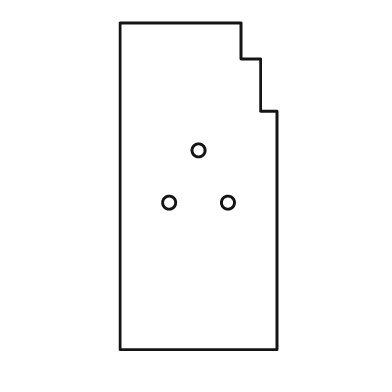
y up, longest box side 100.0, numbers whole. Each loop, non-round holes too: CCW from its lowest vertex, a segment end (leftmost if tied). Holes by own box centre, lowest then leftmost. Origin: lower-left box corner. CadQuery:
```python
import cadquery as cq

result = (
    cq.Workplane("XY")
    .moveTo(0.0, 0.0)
    .lineTo(48.0, 0.0)
    .lineTo(48.0, 73.0)
    .lineTo(43.0, 73.0)
    .lineTo(43.0, 89.0)
    .lineTo(37.0, 89.0)
    .lineTo(37.0, 100.0)
    .lineTo(0.0, 100.0)
    .close()
    .moveTo(15.0, 45.0)
    .circle(2.0)
    .moveTo(33.0, 45.0)
    .circle(2.0)
    .moveTo(24.0, 61.0)
    .circle(2.0)
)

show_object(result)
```